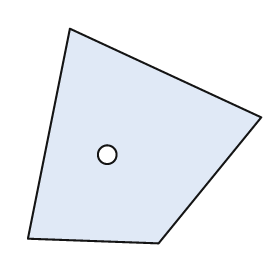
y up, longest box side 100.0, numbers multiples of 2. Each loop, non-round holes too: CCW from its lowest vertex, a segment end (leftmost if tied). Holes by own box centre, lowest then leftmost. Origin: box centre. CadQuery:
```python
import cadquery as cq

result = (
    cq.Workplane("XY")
    .moveTo(6.0, -46.0)
    .lineTo(50.0, 8.0)
    .lineTo(-32.0, 46.0)
    .lineTo(-50.0, -44.0)
    .close()
    .moveTo(-16.0, -8.0)
    .circle(4.0)
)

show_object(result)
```